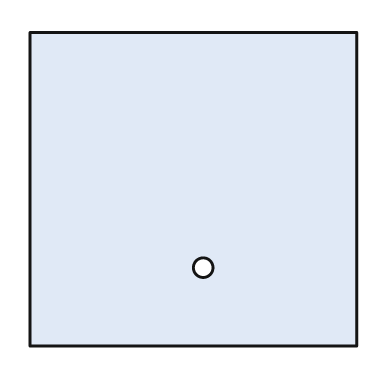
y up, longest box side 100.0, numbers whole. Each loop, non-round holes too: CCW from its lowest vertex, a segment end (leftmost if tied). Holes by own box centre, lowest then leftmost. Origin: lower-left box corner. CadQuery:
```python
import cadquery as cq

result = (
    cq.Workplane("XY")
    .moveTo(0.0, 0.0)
    .lineTo(100.0, 0.0)
    .lineTo(100.0, 96.0)
    .lineTo(0.0, 96.0)
    .close()
    .moveTo(53.0, 24.0)
    .circle(3.0)
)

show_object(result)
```